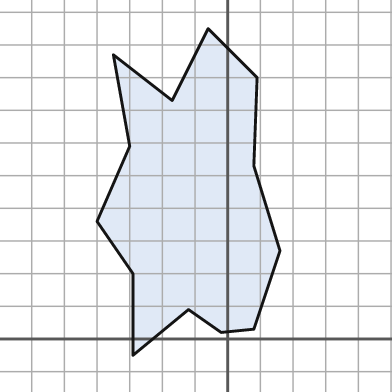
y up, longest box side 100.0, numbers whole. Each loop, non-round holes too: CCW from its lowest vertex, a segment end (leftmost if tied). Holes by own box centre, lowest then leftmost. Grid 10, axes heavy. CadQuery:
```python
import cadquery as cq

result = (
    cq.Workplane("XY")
    .moveTo(-29.0, -5.0)
    .lineTo(-12.0, 9.0)
    .lineTo(-2.0, 2.0)
    .lineTo(8.0, 3.0)
    .lineTo(16.0, 27.0)
    .lineTo(8.0, 53.0)
    .lineTo(9.0, 80.0)
    .lineTo(-6.0, 95.0)
    .lineTo(-17.0, 73.0)
    .lineTo(-35.0, 87.0)
    .lineTo(-30.0, 59.0)
    .lineTo(-40.0, 36.0)
    .lineTo(-29.0, 20.0)
    .close()
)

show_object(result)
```